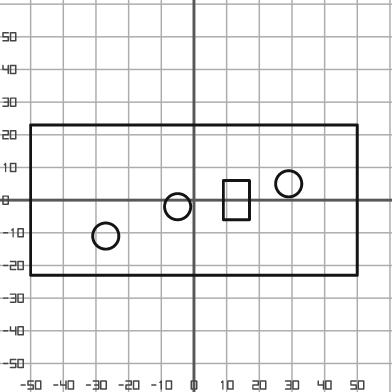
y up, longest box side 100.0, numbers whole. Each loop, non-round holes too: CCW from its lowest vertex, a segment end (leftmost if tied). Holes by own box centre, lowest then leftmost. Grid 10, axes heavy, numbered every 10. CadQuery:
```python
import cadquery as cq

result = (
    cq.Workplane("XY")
    .moveTo(-50.0, -23.0)
    .lineTo(50.0, -23.0)
    .lineTo(50.0, 23.0)
    .lineTo(-50.0, 23.0)
    .close()
    .moveTo(-27.0, -11.0)
    .circle(4.0)
    .moveTo(-5.0, -2.0)
    .circle(4.0)
    .moveTo(9.0, -6.0)
    .lineTo(17.0, -6.0)
    .lineTo(17.0, 6.0)
    .lineTo(9.0, 6.0)
    .close()
    .moveTo(29.0, 5.0)
    .circle(4.0)
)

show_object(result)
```